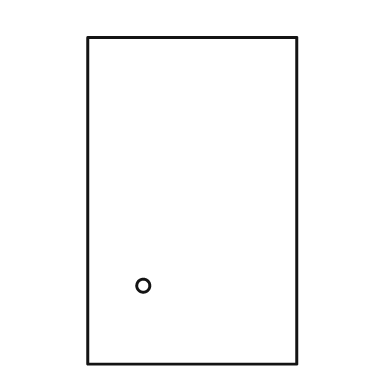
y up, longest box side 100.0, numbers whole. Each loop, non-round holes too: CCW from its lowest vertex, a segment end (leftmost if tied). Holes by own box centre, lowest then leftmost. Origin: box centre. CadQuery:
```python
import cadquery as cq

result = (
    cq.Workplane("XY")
    .moveTo(-32.0, -50.0)
    .lineTo(32.0, -50.0)
    .lineTo(32.0, 50.0)
    .lineTo(-32.0, 50.0)
    .close()
    .moveTo(-15.0, -26.0)
    .circle(2.0)
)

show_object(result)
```